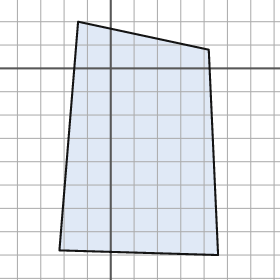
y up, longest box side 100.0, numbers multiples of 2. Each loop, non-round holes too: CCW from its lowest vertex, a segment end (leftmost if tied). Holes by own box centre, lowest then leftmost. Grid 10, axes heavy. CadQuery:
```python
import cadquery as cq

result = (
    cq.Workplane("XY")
    .moveTo(46.0, -80.0)
    .lineTo(42.0, 8.0)
    .lineTo(-14.0, 20.0)
    .lineTo(-22.0, -78.0)
    .close()
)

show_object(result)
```